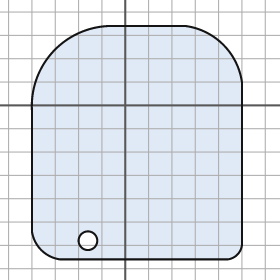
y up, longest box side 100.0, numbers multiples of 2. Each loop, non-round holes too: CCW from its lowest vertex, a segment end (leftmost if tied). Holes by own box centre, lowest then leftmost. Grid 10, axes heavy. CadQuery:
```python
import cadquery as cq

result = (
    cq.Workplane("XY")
    .moveTo(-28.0, -66.0)
    .lineTo(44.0, -66.0)
    .threePointArc((48.0, -64.0), (50.0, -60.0))
    .lineTo(50.0, 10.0)
    .threePointArc((42.0, 26.0), (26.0, 34.0))
    .lineTo(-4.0, 34.0)
    .threePointArc((-30.0, 24.0), (-40.0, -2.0))
    .lineTo(-40.0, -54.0)
    .threePointArc((-36.0, -62.0), (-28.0, -66.0))
    .close()
    .moveTo(-16.0, -58.0)
    .circle(4.0)
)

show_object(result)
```